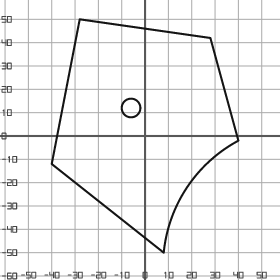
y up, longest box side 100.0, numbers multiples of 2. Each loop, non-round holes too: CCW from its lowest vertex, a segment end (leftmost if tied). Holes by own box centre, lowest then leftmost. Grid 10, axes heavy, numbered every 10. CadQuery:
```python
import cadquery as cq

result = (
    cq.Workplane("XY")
    .moveTo(8.0, -50.0)
    .threePointArc((18.0, -22.0), (40.0, -2.0))
    .lineTo(28.0, 42.0)
    .lineTo(-28.0, 50.0)
    .lineTo(-40.0, -12.0)
    .close()
    .moveTo(-6.0, 12.0)
    .circle(4.0)
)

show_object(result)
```